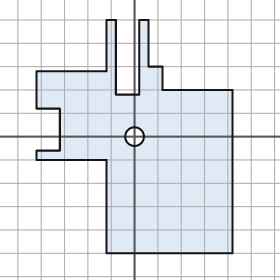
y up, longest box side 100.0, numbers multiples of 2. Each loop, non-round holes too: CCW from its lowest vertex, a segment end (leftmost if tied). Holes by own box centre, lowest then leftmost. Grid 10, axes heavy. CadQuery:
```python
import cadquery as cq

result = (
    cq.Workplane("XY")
    .moveTo(-12.0, -50.0)
    .lineTo(42.0, -50.0)
    .lineTo(42.0, 20.0)
    .lineTo(12.0, 20.0)
    .lineTo(12.0, 30.0)
    .lineTo(6.0, 30.0)
    .lineTo(6.0, 50.0)
    .lineTo(2.0, 50.0)
    .lineTo(2.0, 18.0)
    .lineTo(-8.0, 18.0)
    .lineTo(-8.0, 50.0)
    .lineTo(-12.0, 50.0)
    .lineTo(-12.0, 28.0)
    .lineTo(-42.0, 28.0)
    .lineTo(-42.0, 12.0)
    .lineTo(-32.0, 12.0)
    .lineTo(-32.0, -6.0)
    .lineTo(-42.0, -6.0)
    .lineTo(-42.0, -10.0)
    .lineTo(-12.0, -10.0)
    .close()
    .moveTo(0.0, 0.0)
    .circle(4.0)
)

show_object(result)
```